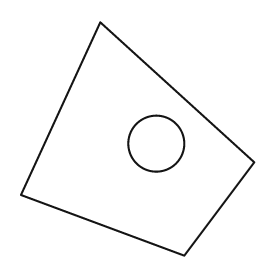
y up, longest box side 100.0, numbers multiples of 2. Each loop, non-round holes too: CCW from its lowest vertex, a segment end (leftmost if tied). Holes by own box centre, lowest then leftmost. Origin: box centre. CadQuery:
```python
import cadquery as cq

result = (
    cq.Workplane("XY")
    .moveTo(20.0, -50.0)
    .lineTo(50.0, -10.0)
    .lineTo(-16.0, 50.0)
    .lineTo(-50.0, -24.0)
    .close()
    .moveTo(8.0, -2.0)
    .circle(12.0)
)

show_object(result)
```